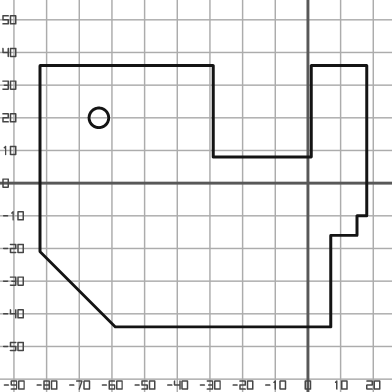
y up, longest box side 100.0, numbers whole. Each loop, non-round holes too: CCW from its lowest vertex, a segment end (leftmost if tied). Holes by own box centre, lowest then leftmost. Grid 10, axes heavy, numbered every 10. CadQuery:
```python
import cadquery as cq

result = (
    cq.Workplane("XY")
    .moveTo(-59.0, -44.0)
    .lineTo(7.0, -44.0)
    .lineTo(7.0, -16.0)
    .lineTo(15.0, -16.0)
    .lineTo(15.0, -10.0)
    .lineTo(18.0, -10.0)
    .lineTo(18.0, 36.0)
    .lineTo(1.0, 36.0)
    .lineTo(1.0, 8.0)
    .lineTo(-29.0, 8.0)
    .lineTo(-29.0, 36.0)
    .lineTo(-82.0, 36.0)
    .lineTo(-82.0, -21.0)
    .close()
    .moveTo(-64.0, 20.0)
    .circle(3.0)
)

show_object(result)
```